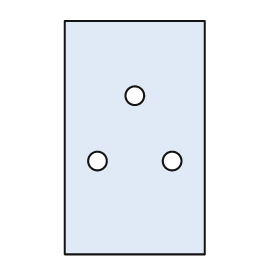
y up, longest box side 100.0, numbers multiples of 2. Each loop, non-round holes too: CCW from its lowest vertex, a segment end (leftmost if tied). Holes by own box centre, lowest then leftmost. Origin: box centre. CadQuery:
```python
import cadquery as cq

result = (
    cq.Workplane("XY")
    .moveTo(-30.0, -50.0)
    .lineTo(30.0, -50.0)
    .lineTo(30.0, 50.0)
    .lineTo(-30.0, 50.0)
    .close()
    .moveTo(-16.0, -10.0)
    .circle(4.0)
    .moveTo(16.0, -10.0)
    .circle(4.0)
    .moveTo(0.0, 18.0)
    .circle(4.0)
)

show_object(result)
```